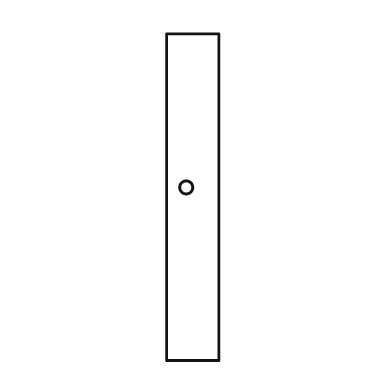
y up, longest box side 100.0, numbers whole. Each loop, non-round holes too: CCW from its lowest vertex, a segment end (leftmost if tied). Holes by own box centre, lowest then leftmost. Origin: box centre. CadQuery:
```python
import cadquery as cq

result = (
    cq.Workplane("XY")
    .moveTo(-8.0, -50.0)
    .lineTo(8.0, -50.0)
    .lineTo(8.0, 50.0)
    .lineTo(-8.0, 50.0)
    .close()
    .moveTo(-2.0, 3.0)
    .circle(2.0)
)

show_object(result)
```